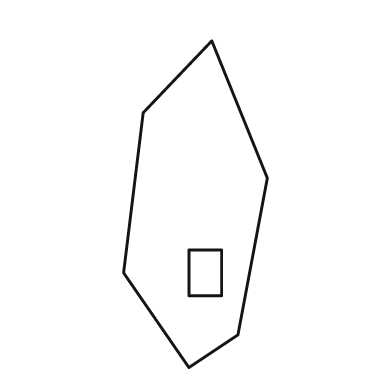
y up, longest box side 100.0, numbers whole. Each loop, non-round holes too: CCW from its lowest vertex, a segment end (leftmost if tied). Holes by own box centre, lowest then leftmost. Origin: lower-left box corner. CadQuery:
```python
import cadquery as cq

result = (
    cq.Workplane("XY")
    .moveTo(20.0, 0.0)
    .lineTo(35.0, 10.0)
    .lineTo(44.0, 58.0)
    .lineTo(27.0, 100.0)
    .lineTo(6.0, 78.0)
    .lineTo(0.0, 29.0)
    .close()
    .moveTo(20.0, 22.0)
    .lineTo(30.0, 22.0)
    .lineTo(30.0, 36.0)
    .lineTo(20.0, 36.0)
    .close()
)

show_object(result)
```